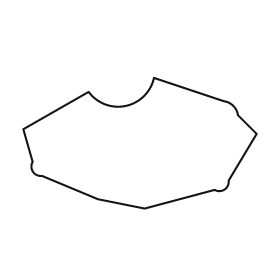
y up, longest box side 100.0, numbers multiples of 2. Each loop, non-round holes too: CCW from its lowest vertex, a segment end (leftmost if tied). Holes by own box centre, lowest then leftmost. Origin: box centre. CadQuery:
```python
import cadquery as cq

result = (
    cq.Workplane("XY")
    .moveTo(2.0, -28.0)
    .lineTo(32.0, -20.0)
    .threePointArc((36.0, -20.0), (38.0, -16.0))
    .lineTo(50.0, 4.0)
    .lineTo(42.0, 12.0)
    .threePointArc((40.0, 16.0), (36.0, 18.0))
    .lineTo(6.0, 28.0)
    .threePointArc((-6.0, 16.0), (-22.0, 22.0))
    .lineTo(-50.0, 6.0)
    .lineTo(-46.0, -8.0)
    .threePointArc((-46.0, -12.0), (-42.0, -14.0))
    .lineTo(-18.0, -24.0)
    .close()
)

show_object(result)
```